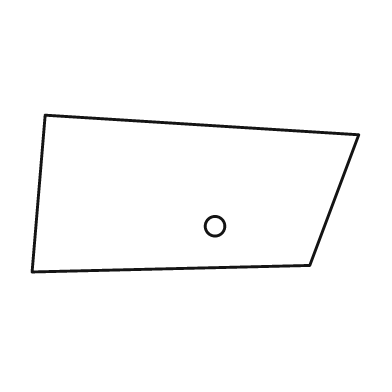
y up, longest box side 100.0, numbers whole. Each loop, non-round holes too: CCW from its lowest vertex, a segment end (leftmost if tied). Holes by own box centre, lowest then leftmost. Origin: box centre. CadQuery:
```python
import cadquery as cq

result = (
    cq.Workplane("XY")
    .moveTo(-50.0, -24.0)
    .lineTo(35.0, -22.0)
    .lineTo(50.0, 18.0)
    .lineTo(-46.0, 24.0)
    .close()
    .moveTo(6.0, -10.0)
    .circle(3.0)
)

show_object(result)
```